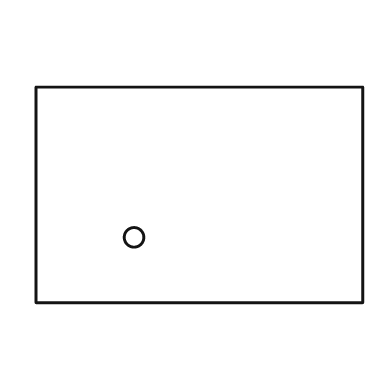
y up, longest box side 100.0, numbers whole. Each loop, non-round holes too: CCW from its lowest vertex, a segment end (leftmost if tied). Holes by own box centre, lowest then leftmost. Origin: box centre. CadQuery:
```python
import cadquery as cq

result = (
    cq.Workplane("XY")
    .moveTo(-50.0, -33.0)
    .lineTo(50.0, -33.0)
    .lineTo(50.0, 33.0)
    .lineTo(-50.0, 33.0)
    .close()
    .moveTo(-20.0, -13.0)
    .circle(3.0)
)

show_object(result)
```